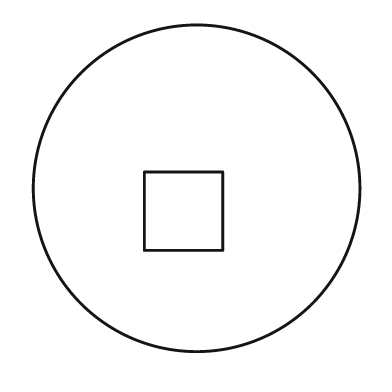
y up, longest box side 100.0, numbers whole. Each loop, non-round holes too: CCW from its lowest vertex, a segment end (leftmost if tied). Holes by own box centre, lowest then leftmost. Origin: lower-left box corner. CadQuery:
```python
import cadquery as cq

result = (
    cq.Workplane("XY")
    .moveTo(50.0, 50.0)
    .circle(50.0)
    .moveTo(34.0, 31.0)
    .lineTo(58.0, 31.0)
    .lineTo(58.0, 55.0)
    .lineTo(34.0, 55.0)
    .close()
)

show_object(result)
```